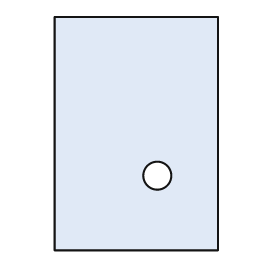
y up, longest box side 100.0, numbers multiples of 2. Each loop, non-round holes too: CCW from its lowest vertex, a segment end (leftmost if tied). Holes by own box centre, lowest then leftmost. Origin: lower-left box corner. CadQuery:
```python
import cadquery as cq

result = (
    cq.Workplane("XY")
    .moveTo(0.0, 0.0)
    .lineTo(70.0, 0.0)
    .lineTo(70.0, 100.0)
    .lineTo(0.0, 100.0)
    .close()
    .moveTo(44.0, 32.0)
    .circle(6.0)
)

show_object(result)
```